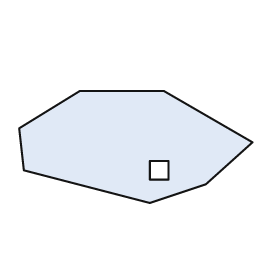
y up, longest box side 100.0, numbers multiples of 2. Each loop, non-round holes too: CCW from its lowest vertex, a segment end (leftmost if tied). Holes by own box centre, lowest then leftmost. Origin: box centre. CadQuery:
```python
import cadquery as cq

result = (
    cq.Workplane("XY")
    .moveTo(6.0, -24.0)
    .lineTo(30.0, -16.0)
    .lineTo(50.0, 2.0)
    .lineTo(12.0, 24.0)
    .lineTo(-24.0, 24.0)
    .lineTo(-50.0, 8.0)
    .lineTo(-48.0, -10.0)
    .close()
    .moveTo(6.0, -14.0)
    .lineTo(14.0, -14.0)
    .lineTo(14.0, -6.0)
    .lineTo(6.0, -6.0)
    .close()
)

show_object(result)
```